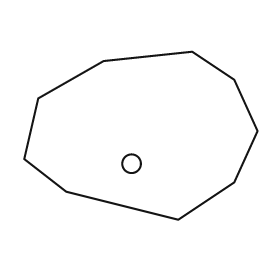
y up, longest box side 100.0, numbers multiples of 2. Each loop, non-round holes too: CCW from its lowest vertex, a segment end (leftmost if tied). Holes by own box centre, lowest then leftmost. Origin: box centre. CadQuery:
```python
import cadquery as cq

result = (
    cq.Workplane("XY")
    .moveTo(16.0, -36.0)
    .lineTo(40.0, -20.0)
    .lineTo(50.0, 2.0)
    .lineTo(40.0, 24.0)
    .lineTo(22.0, 36.0)
    .lineTo(-16.0, 32.0)
    .lineTo(-44.0, 16.0)
    .lineTo(-50.0, -10.0)
    .lineTo(-32.0, -24.0)
    .close()
    .moveTo(-4.0, -12.0)
    .circle(4.0)
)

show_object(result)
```